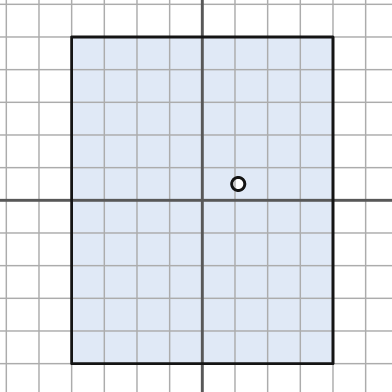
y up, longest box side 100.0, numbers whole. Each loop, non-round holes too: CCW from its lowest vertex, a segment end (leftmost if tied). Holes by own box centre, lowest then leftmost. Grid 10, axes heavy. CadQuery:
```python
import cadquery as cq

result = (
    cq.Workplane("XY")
    .moveTo(-40.0, -50.0)
    .lineTo(40.0, -50.0)
    .lineTo(40.0, 50.0)
    .lineTo(-40.0, 50.0)
    .close()
    .moveTo(11.0, 5.0)
    .circle(2.0)
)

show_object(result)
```